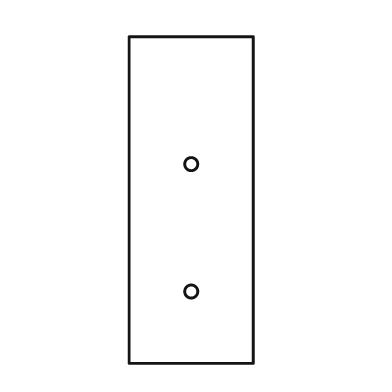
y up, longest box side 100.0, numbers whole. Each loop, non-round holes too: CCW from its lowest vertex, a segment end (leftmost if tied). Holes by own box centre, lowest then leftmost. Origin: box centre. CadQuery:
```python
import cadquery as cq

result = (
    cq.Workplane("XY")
    .moveTo(-19.0, -50.0)
    .lineTo(19.0, -50.0)
    .lineTo(19.0, 50.0)
    .lineTo(-19.0, 50.0)
    .close()
    .moveTo(0.0, -28.0)
    .circle(2.0)
    .moveTo(0.0, 11.0)
    .circle(2.0)
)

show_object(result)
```